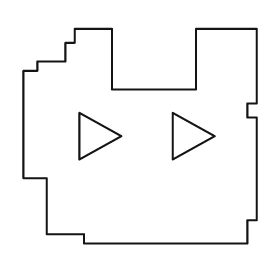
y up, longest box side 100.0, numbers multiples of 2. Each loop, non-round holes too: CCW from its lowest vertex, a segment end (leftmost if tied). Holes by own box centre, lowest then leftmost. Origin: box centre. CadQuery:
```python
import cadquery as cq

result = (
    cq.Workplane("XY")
    .moveTo(-24.0, -46.0)
    .lineTo(46.0, -46.0)
    .lineTo(46.0, -36.0)
    .lineTo(50.0, -36.0)
    .lineTo(50.0, 8.0)
    .lineTo(46.0, 8.0)
    .lineTo(46.0, 14.0)
    .lineTo(50.0, 14.0)
    .lineTo(50.0, 46.0)
    .lineTo(24.0, 46.0)
    .lineTo(24.0, 20.0)
    .lineTo(-12.0, 20.0)
    .lineTo(-12.0, 46.0)
    .lineTo(-28.0, 46.0)
    .lineTo(-28.0, 40.0)
    .lineTo(-32.0, 40.0)
    .lineTo(-32.0, 32.0)
    .lineTo(-44.0, 32.0)
    .lineTo(-44.0, 28.0)
    .lineTo(-50.0, 28.0)
    .lineTo(-50.0, -18.0)
    .lineTo(-40.0, -18.0)
    .lineTo(-40.0, -42.0)
    .lineTo(-24.0, -42.0)
    .close()
    .moveTo(-26.0, -10.0)
    .lineTo(-8.0, 0.0)
    .lineTo(-26.0, 10.0)
    .close()
    .moveTo(14.0, -10.0)
    .lineTo(32.0, 0.0)
    .lineTo(14.0, 10.0)
    .close()
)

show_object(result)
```